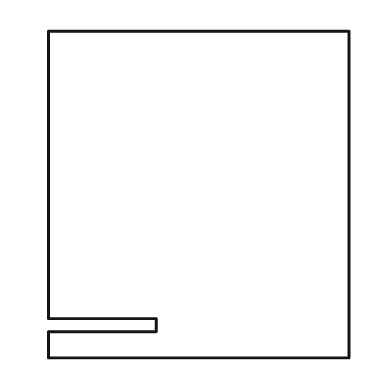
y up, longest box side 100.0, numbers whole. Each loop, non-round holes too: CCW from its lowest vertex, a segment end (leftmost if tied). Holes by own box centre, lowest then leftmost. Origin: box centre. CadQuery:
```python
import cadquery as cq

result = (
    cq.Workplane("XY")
    .moveTo(-46.0, -50.0)
    .lineTo(46.0, -50.0)
    .lineTo(46.0, 50.0)
    .lineTo(-46.0, 50.0)
    .lineTo(-46.0, -38.0)
    .lineTo(-13.0, -38.0)
    .lineTo(-13.0, -42.0)
    .lineTo(-46.0, -42.0)
    .close()
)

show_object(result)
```